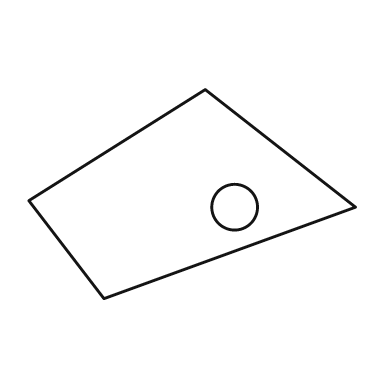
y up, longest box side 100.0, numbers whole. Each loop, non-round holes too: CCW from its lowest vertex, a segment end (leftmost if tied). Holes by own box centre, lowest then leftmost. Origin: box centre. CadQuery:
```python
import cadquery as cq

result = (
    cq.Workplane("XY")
    .moveTo(-27.0, -32.0)
    .lineTo(50.0, -4.0)
    .lineTo(4.0, 32.0)
    .lineTo(-50.0, -2.0)
    .close()
    .moveTo(13.0, -4.0)
    .circle(7.0)
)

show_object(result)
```